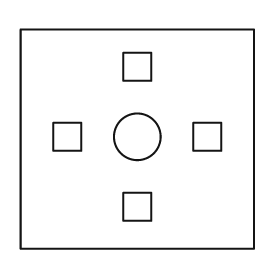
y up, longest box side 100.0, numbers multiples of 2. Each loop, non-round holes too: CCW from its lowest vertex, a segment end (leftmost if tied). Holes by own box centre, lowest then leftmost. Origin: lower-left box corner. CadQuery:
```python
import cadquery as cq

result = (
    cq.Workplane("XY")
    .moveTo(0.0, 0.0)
    .lineTo(100.0, 0.0)
    .lineTo(100.0, 94.0)
    .lineTo(0.0, 94.0)
    .close()
    .moveTo(44.0, 12.0)
    .lineTo(56.0, 12.0)
    .lineTo(56.0, 24.0)
    .lineTo(44.0, 24.0)
    .close()
    .moveTo(14.0, 42.0)
    .lineTo(26.0, 42.0)
    .lineTo(26.0, 54.0)
    .lineTo(14.0, 54.0)
    .close()
    .moveTo(50.0, 48.0)
    .circle(10.0)
    .moveTo(74.0, 42.0)
    .lineTo(86.0, 42.0)
    .lineTo(86.0, 54.0)
    .lineTo(74.0, 54.0)
    .close()
    .moveTo(44.0, 72.0)
    .lineTo(56.0, 72.0)
    .lineTo(56.0, 84.0)
    .lineTo(44.0, 84.0)
    .close()
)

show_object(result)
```